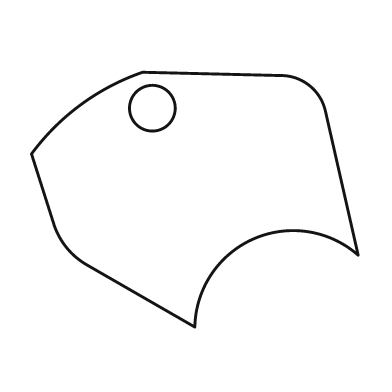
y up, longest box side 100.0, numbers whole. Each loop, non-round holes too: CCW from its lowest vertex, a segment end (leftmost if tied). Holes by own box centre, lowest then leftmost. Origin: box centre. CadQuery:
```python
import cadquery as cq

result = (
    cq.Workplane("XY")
    .moveTo(0.0, -39.0)
    .threePointArc((18.0, -12.0), (50.0, -17.0))
    .lineTo(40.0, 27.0)
    .threePointArc((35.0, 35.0), (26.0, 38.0))
    .lineTo(-16.0, 39.0)
    .threePointArc((-35.0, 29.0), (-50.0, 14.0))
    .lineTo(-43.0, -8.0)
    .threePointArc((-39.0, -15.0), (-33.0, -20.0))
    .close()
    .moveTo(-13.0, 28.0)
    .circle(7.0)
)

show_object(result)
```